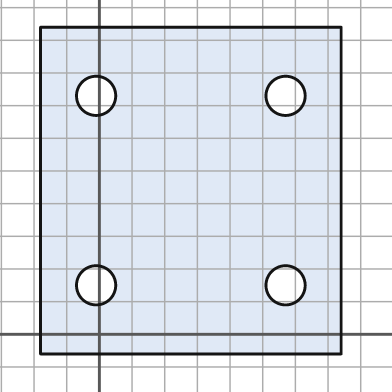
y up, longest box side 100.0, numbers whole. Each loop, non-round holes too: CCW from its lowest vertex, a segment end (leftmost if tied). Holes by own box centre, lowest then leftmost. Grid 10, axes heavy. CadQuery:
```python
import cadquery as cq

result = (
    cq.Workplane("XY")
    .moveTo(-18.0, -6.0)
    .lineTo(74.0, -6.0)
    .lineTo(74.0, 94.0)
    .lineTo(-18.0, 94.0)
    .close()
    .moveTo(-1.0, 15.0)
    .circle(6.0)
    .moveTo(57.0, 15.0)
    .circle(6.0)
    .moveTo(-1.0, 73.0)
    .circle(6.0)
    .moveTo(57.0, 73.0)
    .circle(6.0)
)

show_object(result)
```